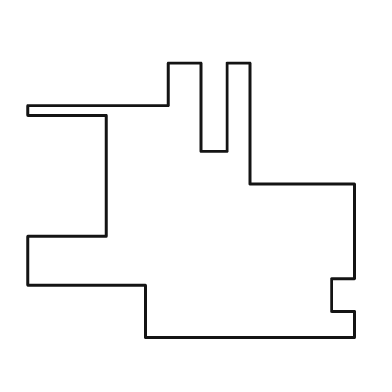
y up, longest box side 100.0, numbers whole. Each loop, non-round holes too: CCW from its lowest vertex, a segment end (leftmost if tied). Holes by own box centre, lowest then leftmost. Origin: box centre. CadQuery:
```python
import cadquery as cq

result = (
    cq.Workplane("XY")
    .moveTo(-14.0, -42.0)
    .lineTo(50.0, -42.0)
    .lineTo(50.0, -34.0)
    .lineTo(43.0, -34.0)
    .lineTo(43.0, -24.0)
    .lineTo(50.0, -24.0)
    .lineTo(50.0, 5.0)
    .lineTo(18.0, 5.0)
    .lineTo(18.0, 42.0)
    .lineTo(11.0, 42.0)
    .lineTo(11.0, 15.0)
    .lineTo(3.0, 15.0)
    .lineTo(3.0, 42.0)
    .lineTo(-7.0, 42.0)
    .lineTo(-7.0, 29.0)
    .lineTo(-50.0, 29.0)
    .lineTo(-50.0, 26.0)
    .lineTo(-26.0, 26.0)
    .lineTo(-26.0, -11.0)
    .lineTo(-50.0, -11.0)
    .lineTo(-50.0, -26.0)
    .lineTo(-14.0, -26.0)
    .close()
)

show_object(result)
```